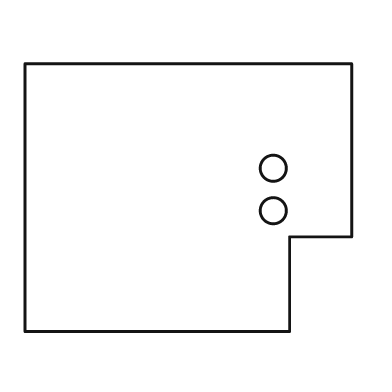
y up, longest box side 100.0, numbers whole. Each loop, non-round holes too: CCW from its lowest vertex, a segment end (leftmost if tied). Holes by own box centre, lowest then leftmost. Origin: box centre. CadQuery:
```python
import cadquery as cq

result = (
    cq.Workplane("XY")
    .moveTo(-50.0, -41.0)
    .lineTo(31.0, -41.0)
    .lineTo(31.0, -12.0)
    .lineTo(50.0, -12.0)
    .lineTo(50.0, 41.0)
    .lineTo(-50.0, 41.0)
    .close()
    .moveTo(26.0, -4.0)
    .circle(4.0)
    .moveTo(26.0, 9.0)
    .circle(4.0)
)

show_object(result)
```